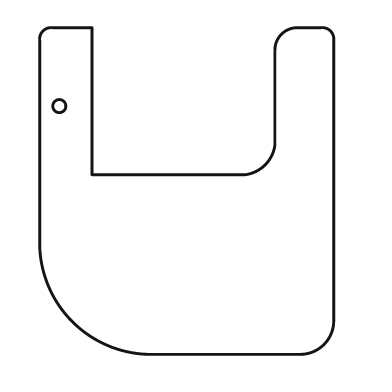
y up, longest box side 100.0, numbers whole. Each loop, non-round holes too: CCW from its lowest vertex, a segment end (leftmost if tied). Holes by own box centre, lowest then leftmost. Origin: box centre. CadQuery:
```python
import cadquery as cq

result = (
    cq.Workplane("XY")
    .moveTo(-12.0, -50.0)
    .lineTo(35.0, -50.0)
    .threePointArc((42.0, -47.0), (45.0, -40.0))
    .lineTo(45.0, 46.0)
    .threePointArc((44.0, 49.0), (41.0, 50.0))
    .lineTo(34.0, 50.0)
    .threePointArc((29.0, 48.0), (27.0, 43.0))
    .lineTo(27.0, 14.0)
    .threePointArc((24.0, 8.0), (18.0, 5.0))
    .lineTo(-29.0, 5.0)
    .lineTo(-29.0, 50.0)
    .lineTo(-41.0, 50.0)
    .threePointArc((-44.0, 49.0), (-45.0, 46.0))
    .lineTo(-45.0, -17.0)
    .threePointArc((-35.0, -40.0), (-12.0, -50.0))
    .close()
    .moveTo(-39.0, 26.0)
    .circle(2.0)
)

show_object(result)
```